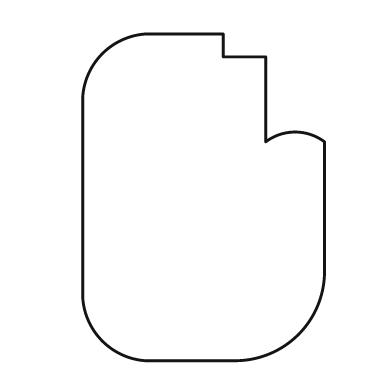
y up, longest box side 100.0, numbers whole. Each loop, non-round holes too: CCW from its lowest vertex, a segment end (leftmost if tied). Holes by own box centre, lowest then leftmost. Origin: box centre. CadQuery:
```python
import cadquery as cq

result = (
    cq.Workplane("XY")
    .moveTo(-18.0, -50.0)
    .lineTo(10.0, -50.0)
    .threePointArc((29.0, -42.0), (37.0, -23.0))
    .lineTo(37.0, 17.0)
    .threePointArc((28.0, 20.0), (19.0, 17.0))
    .lineTo(19.0, 43.0)
    .lineTo(6.0, 43.0)
    .lineTo(6.0, 50.0)
    .lineTo(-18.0, 50.0)
    .threePointArc((-31.0, 44.0), (-37.0, 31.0))
    .lineTo(-37.0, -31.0)
    .threePointArc((-31.0, -44.0), (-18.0, -50.0))
    .close()
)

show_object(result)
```